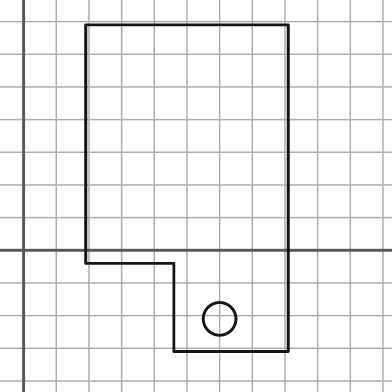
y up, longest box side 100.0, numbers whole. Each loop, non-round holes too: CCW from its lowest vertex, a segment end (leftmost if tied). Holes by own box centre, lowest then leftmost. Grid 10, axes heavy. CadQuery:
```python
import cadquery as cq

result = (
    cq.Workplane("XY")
    .moveTo(46.0, -31.0)
    .lineTo(81.0, -31.0)
    .lineTo(81.0, 69.0)
    .lineTo(19.0, 69.0)
    .lineTo(19.0, -4.0)
    .lineTo(46.0, -4.0)
    .close()
    .moveTo(60.0, -21.0)
    .circle(5.0)
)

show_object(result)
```